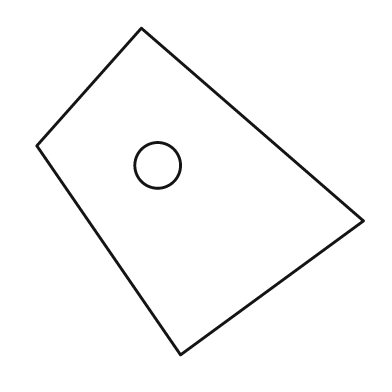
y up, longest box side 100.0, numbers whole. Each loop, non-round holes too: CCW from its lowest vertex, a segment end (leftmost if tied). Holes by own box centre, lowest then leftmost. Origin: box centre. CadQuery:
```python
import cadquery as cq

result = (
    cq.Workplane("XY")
    .moveTo(-6.0, -50.0)
    .lineTo(50.0, -9.0)
    .lineTo(-18.0, 50.0)
    .lineTo(-50.0, 14.0)
    .close()
    .moveTo(-13.0, 8.0)
    .circle(7.0)
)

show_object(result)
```